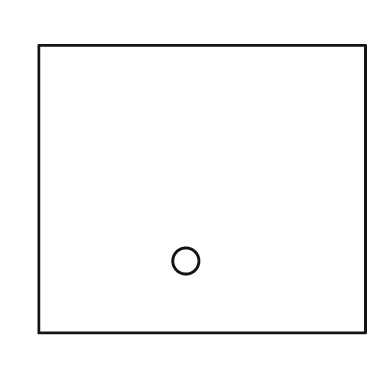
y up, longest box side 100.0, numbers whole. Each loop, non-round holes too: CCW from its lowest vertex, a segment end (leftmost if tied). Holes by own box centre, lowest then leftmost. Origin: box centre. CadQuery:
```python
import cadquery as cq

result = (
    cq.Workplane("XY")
    .moveTo(-50.0, -44.0)
    .lineTo(50.0, -44.0)
    .lineTo(50.0, 44.0)
    .lineTo(-50.0, 44.0)
    .close()
    .moveTo(-5.0, -22.0)
    .circle(4.0)
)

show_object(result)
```